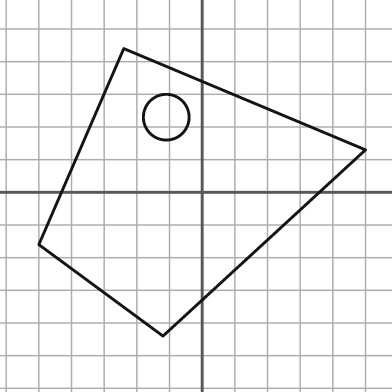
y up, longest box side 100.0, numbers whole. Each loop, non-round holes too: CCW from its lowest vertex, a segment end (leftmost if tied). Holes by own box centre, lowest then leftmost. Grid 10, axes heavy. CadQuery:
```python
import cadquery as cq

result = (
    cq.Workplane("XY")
    .moveTo(-12.0, -44.0)
    .lineTo(50.0, 13.0)
    .lineTo(-24.0, 44.0)
    .lineTo(-50.0, -16.0)
    .close()
    .moveTo(-11.0, 23.0)
    .circle(7.0)
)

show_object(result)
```